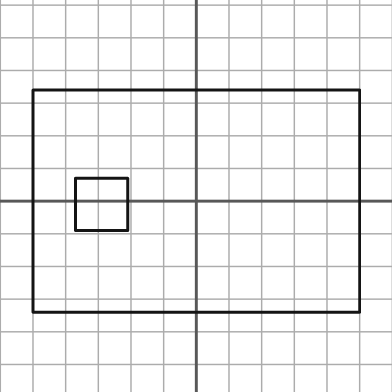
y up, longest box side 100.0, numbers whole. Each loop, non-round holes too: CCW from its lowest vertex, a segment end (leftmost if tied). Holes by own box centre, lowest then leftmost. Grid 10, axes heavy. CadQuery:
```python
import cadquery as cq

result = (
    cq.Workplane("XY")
    .moveTo(-50.0, -34.0)
    .lineTo(50.0, -34.0)
    .lineTo(50.0, 34.0)
    .lineTo(-50.0, 34.0)
    .close()
    .moveTo(-37.0, -9.0)
    .lineTo(-21.0, -9.0)
    .lineTo(-21.0, 7.0)
    .lineTo(-37.0, 7.0)
    .close()
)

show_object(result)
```